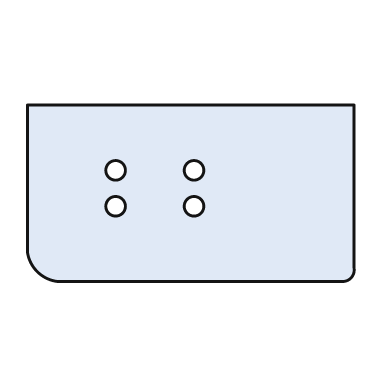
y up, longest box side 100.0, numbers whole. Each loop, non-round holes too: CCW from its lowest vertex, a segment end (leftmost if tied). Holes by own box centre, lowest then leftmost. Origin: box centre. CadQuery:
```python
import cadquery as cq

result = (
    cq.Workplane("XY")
    .moveTo(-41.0, -27.0)
    .lineTo(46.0, -27.0)
    .threePointArc((49.0, -26.0), (50.0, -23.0))
    .lineTo(50.0, 27.0)
    .lineTo(-50.0, 27.0)
    .lineTo(-50.0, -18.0)
    .threePointArc((-47.0, -24.0), (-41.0, -27.0))
    .close()
    .moveTo(-23.0, -4.0)
    .circle(3.0)
    .moveTo(1.0, -4.0)
    .circle(3.0)
    .moveTo(-23.0, 7.0)
    .circle(3.0)
    .moveTo(1.0, 7.0)
    .circle(3.0)
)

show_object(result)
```